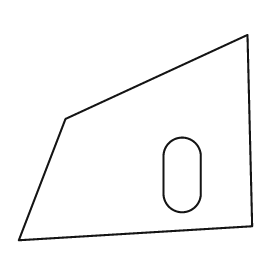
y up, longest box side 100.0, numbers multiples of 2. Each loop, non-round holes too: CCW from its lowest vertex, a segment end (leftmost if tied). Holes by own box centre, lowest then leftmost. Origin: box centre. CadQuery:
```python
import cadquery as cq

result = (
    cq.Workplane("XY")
    .moveTo(-50.0, -44.0)
    .lineTo(50.0, -38.0)
    .lineTo(48.0, 44.0)
    .lineTo(-30.0, 8.0)
    .close()
    .moveTo(12.0, -24.0)
    .threePointArc((20.0, -32.0), (28.0, -24.0))
    .lineTo(28.0, -8.0)
    .threePointArc((20.0, 0.0), (12.0, -8.0))
    .close()
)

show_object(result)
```